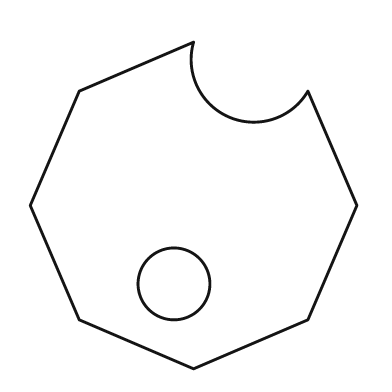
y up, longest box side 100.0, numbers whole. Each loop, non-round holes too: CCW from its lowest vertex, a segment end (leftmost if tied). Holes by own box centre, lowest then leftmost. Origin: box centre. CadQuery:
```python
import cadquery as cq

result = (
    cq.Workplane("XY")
    .moveTo(0.0, -50.0)
    .lineTo(35.0, -35.0)
    .lineTo(50.0, 0.0)
    .lineTo(35.0, 35.0)
    .threePointArc((11.0, 27.0), (0.0, 50.0))
    .lineTo(-35.0, 35.0)
    .lineTo(-50.0, 0.0)
    .lineTo(-35.0, -35.0)
    .close()
    .moveTo(-6.0, -24.0)
    .circle(11.0)
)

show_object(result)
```